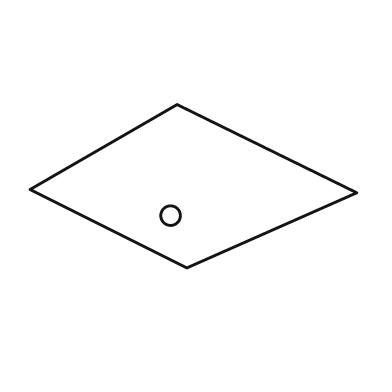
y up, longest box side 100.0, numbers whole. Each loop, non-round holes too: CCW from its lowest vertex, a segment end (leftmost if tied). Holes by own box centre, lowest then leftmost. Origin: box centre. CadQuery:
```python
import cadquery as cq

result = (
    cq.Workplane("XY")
    .moveTo(-2.0, -25.0)
    .lineTo(50.0, -2.0)
    .lineTo(-5.0, 25.0)
    .lineTo(-50.0, -1.0)
    .close()
    .moveTo(-7.0, -9.0)
    .circle(3.0)
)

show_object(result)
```